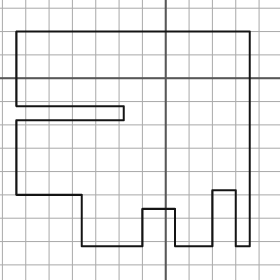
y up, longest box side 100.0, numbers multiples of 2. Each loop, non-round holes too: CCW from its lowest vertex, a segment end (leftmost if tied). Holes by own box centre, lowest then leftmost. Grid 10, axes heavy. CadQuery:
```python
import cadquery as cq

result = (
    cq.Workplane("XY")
    .moveTo(-36.0, -72.0)
    .lineTo(-10.0, -72.0)
    .lineTo(-10.0, -56.0)
    .lineTo(4.0, -56.0)
    .lineTo(4.0, -72.0)
    .lineTo(20.0, -72.0)
    .lineTo(20.0, -48.0)
    .lineTo(30.0, -48.0)
    .lineTo(30.0, -72.0)
    .lineTo(36.0, -72.0)
    .lineTo(36.0, 20.0)
    .lineTo(-64.0, 20.0)
    .lineTo(-64.0, -12.0)
    .lineTo(-18.0, -12.0)
    .lineTo(-18.0, -18.0)
    .lineTo(-64.0, -18.0)
    .lineTo(-64.0, -50.0)
    .lineTo(-36.0, -50.0)
    .close()
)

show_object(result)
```